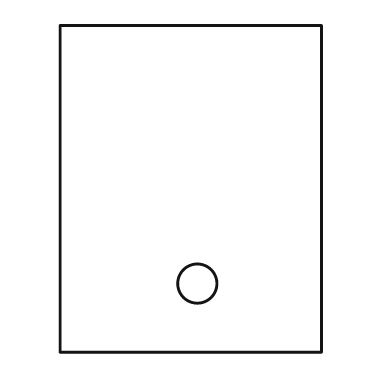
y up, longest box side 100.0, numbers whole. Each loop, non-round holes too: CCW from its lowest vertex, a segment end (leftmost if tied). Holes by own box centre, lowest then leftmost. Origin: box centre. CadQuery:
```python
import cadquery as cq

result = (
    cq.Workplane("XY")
    .moveTo(-40.0, -50.0)
    .lineTo(40.0, -50.0)
    .lineTo(40.0, 50.0)
    .lineTo(-40.0, 50.0)
    .close()
    .moveTo(2.0, -29.0)
    .circle(6.0)
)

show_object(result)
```